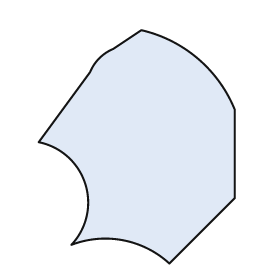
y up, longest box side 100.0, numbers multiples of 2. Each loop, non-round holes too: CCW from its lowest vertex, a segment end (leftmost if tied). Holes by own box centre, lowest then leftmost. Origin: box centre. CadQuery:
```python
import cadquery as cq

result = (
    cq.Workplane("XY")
    .moveTo(14.0, -50.0)
    .lineTo(42.0, -22.0)
    .lineTo(42.0, 16.0)
    .threePointArc((26.0, 38.0), (2.0, 50.0))
    .lineTo(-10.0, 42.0)
    .threePointArc((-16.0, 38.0), (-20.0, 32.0))
    .lineTo(-42.0, 2.0)
    .threePointArc((-22.0, -16.0), (-28.0, -42.0))
    .threePointArc((-6.0, -40.0), (14.0, -50.0))
    .close()
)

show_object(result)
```